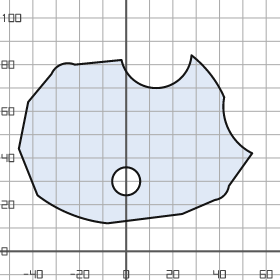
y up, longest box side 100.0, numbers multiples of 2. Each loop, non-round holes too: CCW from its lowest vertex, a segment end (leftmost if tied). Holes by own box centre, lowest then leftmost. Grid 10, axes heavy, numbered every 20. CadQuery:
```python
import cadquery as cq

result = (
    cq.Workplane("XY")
    .moveTo(-8.0, 12.0)
    .lineTo(24.0, 16.0)
    .lineTo(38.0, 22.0)
    .threePointArc((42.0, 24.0), (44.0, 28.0))
    .lineTo(54.0, 42.0)
    .threePointArc((44.0, 52.0), (42.0, 66.0))
    .threePointArc((36.0, 76.0), (28.0, 84.0))
    .threePointArc((14.0, 70.0), (-2.0, 82.0))
    .lineTo(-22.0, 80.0)
    .threePointArc((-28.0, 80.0), (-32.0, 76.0))
    .lineTo(-42.0, 64.0)
    .lineTo(-46.0, 44.0)
    .lineTo(-38.0, 24.0)
    .threePointArc((-24.0, 16.0), (-8.0, 12.0))
    .close()
    .moveTo(0.0, 30.0)
    .circle(6.0)
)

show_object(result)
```